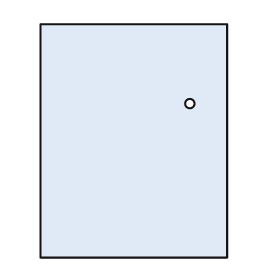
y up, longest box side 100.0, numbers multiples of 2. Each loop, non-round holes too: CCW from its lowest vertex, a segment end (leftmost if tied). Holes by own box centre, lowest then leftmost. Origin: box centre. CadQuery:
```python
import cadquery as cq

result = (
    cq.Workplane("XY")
    .moveTo(-40.0, -50.0)
    .lineTo(40.0, -50.0)
    .lineTo(40.0, 50.0)
    .lineTo(-40.0, 50.0)
    .close()
    .moveTo(24.0, 16.0)
    .circle(2.0)
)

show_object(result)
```